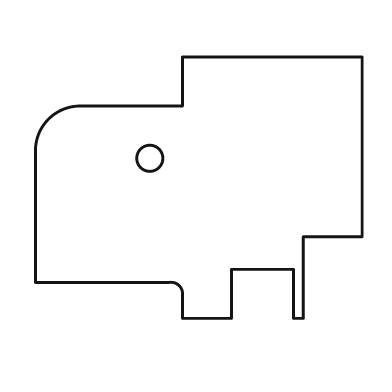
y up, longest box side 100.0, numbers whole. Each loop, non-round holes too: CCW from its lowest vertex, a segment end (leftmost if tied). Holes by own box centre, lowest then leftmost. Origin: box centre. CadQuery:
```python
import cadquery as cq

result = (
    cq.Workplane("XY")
    .moveTo(-5.0, -40.0)
    .lineTo(10.0, -40.0)
    .lineTo(10.0, -25.0)
    .lineTo(29.0, -25.0)
    .lineTo(29.0, -40.0)
    .lineTo(32.0, -40.0)
    .lineTo(32.0, -15.0)
    .lineTo(50.0, -15.0)
    .lineTo(50.0, 40.0)
    .lineTo(-5.0, 40.0)
    .lineTo(-5.0, 25.0)
    .lineTo(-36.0, 25.0)
    .threePointArc((-46.0, 21.0), (-50.0, 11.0))
    .lineTo(-50.0, -29.0)
    .lineTo(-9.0, -29.0)
    .threePointArc((-6.0, -30.0), (-5.0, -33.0))
    .close()
    .moveTo(-15.0, 9.0)
    .circle(4.0)
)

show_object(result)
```